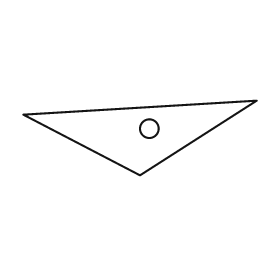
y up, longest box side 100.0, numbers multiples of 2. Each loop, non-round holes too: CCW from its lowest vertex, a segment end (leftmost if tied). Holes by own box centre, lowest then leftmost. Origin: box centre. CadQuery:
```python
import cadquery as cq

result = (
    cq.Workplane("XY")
    .moveTo(0.0, -16.0)
    .lineTo(50.0, 16.0)
    .lineTo(-50.0, 10.0)
    .close()
    .moveTo(4.0, 4.0)
    .circle(4.0)
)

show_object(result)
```